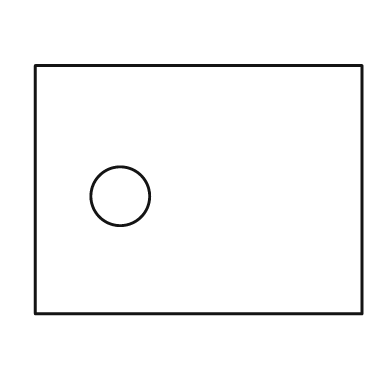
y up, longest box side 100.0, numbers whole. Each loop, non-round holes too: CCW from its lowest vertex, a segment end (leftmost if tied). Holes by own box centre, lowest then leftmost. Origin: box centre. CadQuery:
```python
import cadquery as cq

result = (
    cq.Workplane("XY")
    .moveTo(-50.0, -38.0)
    .lineTo(50.0, -38.0)
    .lineTo(50.0, 38.0)
    .lineTo(-50.0, 38.0)
    .close()
    .moveTo(-24.0, -2.0)
    .circle(9.0)
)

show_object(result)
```